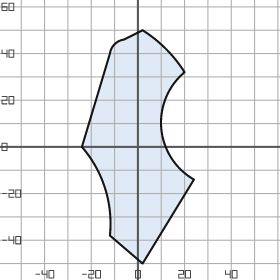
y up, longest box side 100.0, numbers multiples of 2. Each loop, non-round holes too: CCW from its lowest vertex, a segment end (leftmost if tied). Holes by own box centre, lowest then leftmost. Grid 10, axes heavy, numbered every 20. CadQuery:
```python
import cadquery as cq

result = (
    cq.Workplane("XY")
    .moveTo(2.0, -50.0)
    .lineTo(24.0, -14.0)
    .threePointArc((10.0, 8.0), (20.0, 32.0))
    .threePointArc((12.0, 42.0), (2.0, 50.0))
    .lineTo(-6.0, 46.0)
    .threePointArc((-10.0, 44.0), (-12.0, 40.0))
    .lineTo(-24.0, 0.0)
    .threePointArc((-14.0, -18.0), (-12.0, -38.0))
    .close()
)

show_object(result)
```